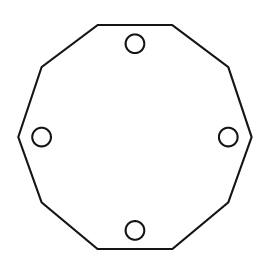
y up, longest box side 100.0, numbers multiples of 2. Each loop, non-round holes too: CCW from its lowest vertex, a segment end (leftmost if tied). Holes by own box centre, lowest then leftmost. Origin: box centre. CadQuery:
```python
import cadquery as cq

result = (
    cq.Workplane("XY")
    .moveTo(-16.0, -48.0)
    .lineTo(16.0, -48.0)
    .lineTo(40.0, -28.0)
    .lineTo(50.0, 0.0)
    .lineTo(40.0, 30.0)
    .lineTo(16.0, 48.0)
    .lineTo(-16.0, 48.0)
    .lineTo(-40.0, 30.0)
    .lineTo(-50.0, 0.0)
    .lineTo(-40.0, -28.0)
    .close()
    .moveTo(0.0, -40.0)
    .circle(4.0)
    .moveTo(-40.0, 0.0)
    .circle(4.0)
    .moveTo(40.0, 0.0)
    .circle(4.0)
    .moveTo(0.0, 40.0)
    .circle(4.0)
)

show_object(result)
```